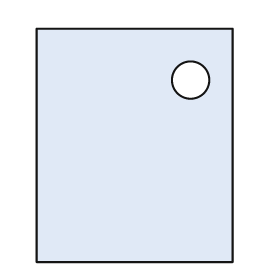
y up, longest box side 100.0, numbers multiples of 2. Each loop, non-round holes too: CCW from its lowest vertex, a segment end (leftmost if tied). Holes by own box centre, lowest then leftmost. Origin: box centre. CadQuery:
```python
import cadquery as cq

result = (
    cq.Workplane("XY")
    .moveTo(-42.0, -50.0)
    .lineTo(42.0, -50.0)
    .lineTo(42.0, 50.0)
    .lineTo(-42.0, 50.0)
    .close()
    .moveTo(24.0, 28.0)
    .circle(8.0)
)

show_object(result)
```